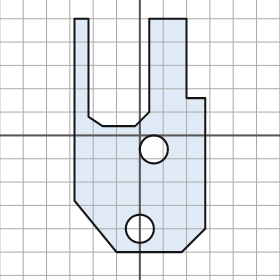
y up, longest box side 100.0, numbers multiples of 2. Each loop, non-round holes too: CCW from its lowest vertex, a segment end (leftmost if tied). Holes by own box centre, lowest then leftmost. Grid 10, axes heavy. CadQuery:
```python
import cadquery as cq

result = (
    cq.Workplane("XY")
    .moveTo(-10.0, -50.0)
    .lineTo(18.0, -50.0)
    .lineTo(28.0, -40.0)
    .lineTo(28.0, 16.0)
    .lineTo(20.0, 16.0)
    .lineTo(20.0, 50.0)
    .lineTo(4.0, 50.0)
    .lineTo(4.0, 10.0)
    .lineTo(-2.0, 4.0)
    .lineTo(-16.0, 4.0)
    .lineTo(-22.0, 8.0)
    .lineTo(-22.0, 50.0)
    .lineTo(-28.0, 50.0)
    .lineTo(-28.0, -28.0)
    .close()
    .moveTo(0.0, -40.0)
    .circle(6.0)
    .moveTo(6.0, -6.0)
    .circle(6.0)
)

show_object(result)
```